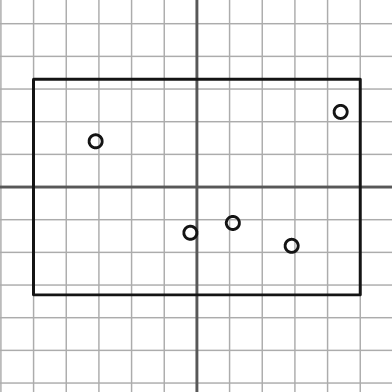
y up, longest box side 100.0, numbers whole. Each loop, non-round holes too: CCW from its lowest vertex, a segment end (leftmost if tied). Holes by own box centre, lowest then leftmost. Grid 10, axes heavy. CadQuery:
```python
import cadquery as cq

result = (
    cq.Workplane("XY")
    .moveTo(-50.0, -33.0)
    .lineTo(50.0, -33.0)
    .lineTo(50.0, 33.0)
    .lineTo(-50.0, 33.0)
    .close()
    .moveTo(29.0, -18.0)
    .circle(2.0)
    .moveTo(-2.0, -14.0)
    .circle(2.0)
    .moveTo(11.0, -11.0)
    .circle(2.0)
    .moveTo(-31.0, 14.0)
    .circle(2.0)
    .moveTo(44.0, 23.0)
    .circle(2.0)
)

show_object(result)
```